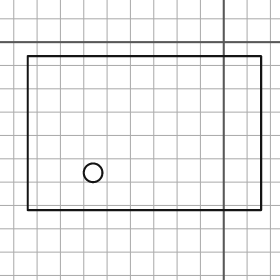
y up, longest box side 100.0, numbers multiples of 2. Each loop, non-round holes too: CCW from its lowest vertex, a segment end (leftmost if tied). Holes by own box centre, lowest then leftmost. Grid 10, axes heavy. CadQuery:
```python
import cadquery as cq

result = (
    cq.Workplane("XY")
    .moveTo(-84.0, -72.0)
    .lineTo(16.0, -72.0)
    .lineTo(16.0, -6.0)
    .lineTo(-84.0, -6.0)
    .close()
    .moveTo(-56.0, -56.0)
    .circle(4.0)
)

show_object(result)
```